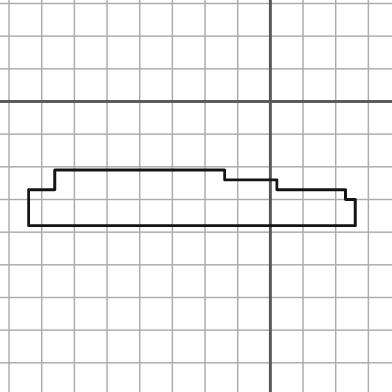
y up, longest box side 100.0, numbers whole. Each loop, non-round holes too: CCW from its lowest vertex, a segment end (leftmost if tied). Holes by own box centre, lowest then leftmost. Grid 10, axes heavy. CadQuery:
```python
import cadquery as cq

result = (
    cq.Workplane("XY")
    .moveTo(-74.0, -38.0)
    .lineTo(26.0, -38.0)
    .lineTo(26.0, -30.0)
    .lineTo(23.0, -30.0)
    .lineTo(23.0, -27.0)
    .lineTo(2.0, -27.0)
    .lineTo(2.0, -24.0)
    .lineTo(-14.0, -24.0)
    .lineTo(-14.0, -21.0)
    .lineTo(-66.0, -21.0)
    .lineTo(-66.0, -27.0)
    .lineTo(-74.0, -27.0)
    .close()
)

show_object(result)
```